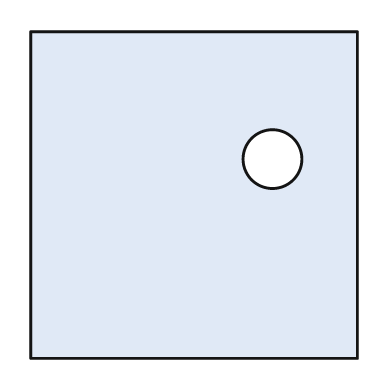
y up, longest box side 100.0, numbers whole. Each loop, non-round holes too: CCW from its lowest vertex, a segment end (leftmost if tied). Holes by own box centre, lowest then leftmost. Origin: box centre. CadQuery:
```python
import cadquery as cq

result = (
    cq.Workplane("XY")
    .moveTo(-50.0, -50.0)
    .lineTo(50.0, -50.0)
    .lineTo(50.0, 50.0)
    .lineTo(-50.0, 50.0)
    .close()
    .moveTo(24.0, 11.0)
    .circle(9.0)
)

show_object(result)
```